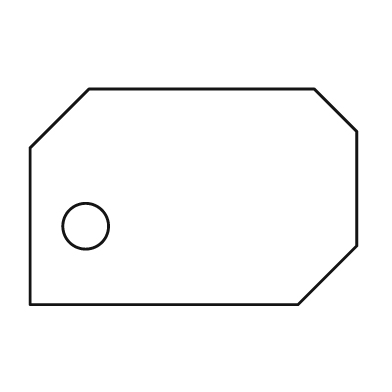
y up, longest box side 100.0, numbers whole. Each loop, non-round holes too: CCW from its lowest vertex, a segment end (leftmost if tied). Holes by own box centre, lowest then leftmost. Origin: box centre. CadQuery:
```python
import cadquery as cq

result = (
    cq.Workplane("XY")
    .moveTo(-50.0, -33.0)
    .lineTo(32.0, -33.0)
    .lineTo(50.0, -15.0)
    .lineTo(50.0, 20.0)
    .lineTo(37.0, 33.0)
    .lineTo(-32.0, 33.0)
    .lineTo(-50.0, 15.0)
    .close()
    .moveTo(-33.0, -9.0)
    .circle(7.0)
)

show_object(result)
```